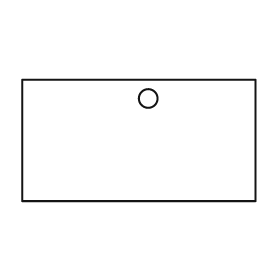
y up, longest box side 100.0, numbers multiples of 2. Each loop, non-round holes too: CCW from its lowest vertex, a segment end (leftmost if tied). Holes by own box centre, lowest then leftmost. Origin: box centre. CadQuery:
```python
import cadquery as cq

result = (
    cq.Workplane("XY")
    .moveTo(-50.0, -26.0)
    .lineTo(50.0, -26.0)
    .lineTo(50.0, 26.0)
    .lineTo(-50.0, 26.0)
    .close()
    .moveTo(4.0, 18.0)
    .circle(4.0)
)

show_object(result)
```